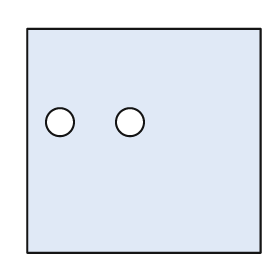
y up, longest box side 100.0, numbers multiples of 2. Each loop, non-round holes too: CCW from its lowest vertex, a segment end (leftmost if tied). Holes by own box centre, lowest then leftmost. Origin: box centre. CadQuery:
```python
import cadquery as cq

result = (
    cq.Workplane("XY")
    .moveTo(-50.0, -48.0)
    .lineTo(50.0, -48.0)
    .lineTo(50.0, 48.0)
    .lineTo(-50.0, 48.0)
    .close()
    .moveTo(-36.0, 8.0)
    .circle(6.0)
    .moveTo(-6.0, 8.0)
    .circle(6.0)
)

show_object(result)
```